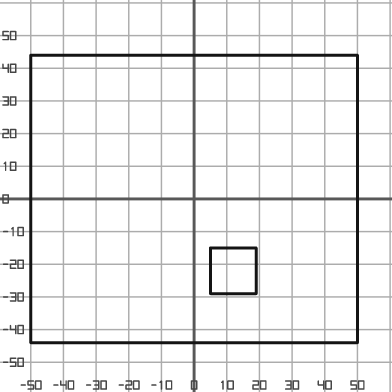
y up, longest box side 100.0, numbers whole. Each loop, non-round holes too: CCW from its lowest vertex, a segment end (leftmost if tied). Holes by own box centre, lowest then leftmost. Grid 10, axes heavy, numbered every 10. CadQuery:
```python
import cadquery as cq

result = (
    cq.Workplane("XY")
    .moveTo(-50.0, -44.0)
    .lineTo(50.0, -44.0)
    .lineTo(50.0, 44.0)
    .lineTo(-50.0, 44.0)
    .close()
    .moveTo(5.0, -29.0)
    .lineTo(19.0, -29.0)
    .lineTo(19.0, -15.0)
    .lineTo(5.0, -15.0)
    .close()
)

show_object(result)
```